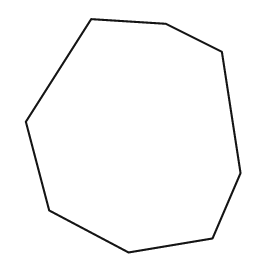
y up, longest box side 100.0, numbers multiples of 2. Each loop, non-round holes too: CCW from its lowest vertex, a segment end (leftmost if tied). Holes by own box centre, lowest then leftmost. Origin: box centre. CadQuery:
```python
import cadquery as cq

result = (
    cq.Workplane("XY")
    .moveTo(-2.0, -50.0)
    .lineTo(34.0, -44.0)
    .lineTo(46.0, -16.0)
    .lineTo(38.0, 36.0)
    .lineTo(14.0, 48.0)
    .lineTo(-18.0, 50.0)
    .lineTo(-46.0, 6.0)
    .lineTo(-36.0, -32.0)
    .close()
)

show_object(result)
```